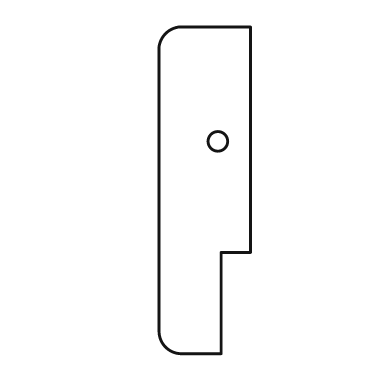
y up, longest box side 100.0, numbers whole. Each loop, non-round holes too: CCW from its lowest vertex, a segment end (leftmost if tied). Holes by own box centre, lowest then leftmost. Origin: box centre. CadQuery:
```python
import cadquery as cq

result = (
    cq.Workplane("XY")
    .moveTo(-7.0, -50.0)
    .lineTo(5.0, -50.0)
    .lineTo(5.0, -19.0)
    .lineTo(14.0, -19.0)
    .lineTo(14.0, 50.0)
    .lineTo(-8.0, 50.0)
    .threePointArc((-12.0, 48.0), (-14.0, 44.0))
    .lineTo(-14.0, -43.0)
    .threePointArc((-12.0, -48.0), (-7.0, -50.0))
    .close()
    .moveTo(4.0, 15.0)
    .circle(3.0)
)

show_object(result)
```